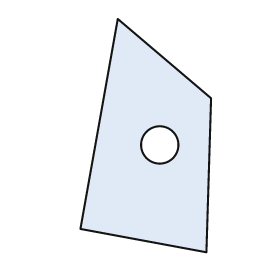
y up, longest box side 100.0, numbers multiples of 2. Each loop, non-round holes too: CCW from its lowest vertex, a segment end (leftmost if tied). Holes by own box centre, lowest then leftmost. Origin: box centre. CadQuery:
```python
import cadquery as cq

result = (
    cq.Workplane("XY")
    .moveTo(26.0, -50.0)
    .lineTo(28.0, 16.0)
    .lineTo(-12.0, 50.0)
    .lineTo(-28.0, -40.0)
    .close()
    .moveTo(6.0, -4.0)
    .circle(8.0)
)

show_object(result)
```